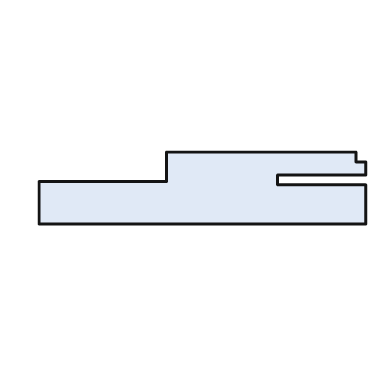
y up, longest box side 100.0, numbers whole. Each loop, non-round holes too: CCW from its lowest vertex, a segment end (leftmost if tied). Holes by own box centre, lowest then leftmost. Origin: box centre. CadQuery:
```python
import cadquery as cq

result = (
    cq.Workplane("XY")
    .moveTo(-50.0, -11.0)
    .lineTo(50.0, -11.0)
    .lineTo(50.0, 1.0)
    .lineTo(23.0, 1.0)
    .lineTo(23.0, 4.0)
    .lineTo(50.0, 4.0)
    .lineTo(50.0, 8.0)
    .lineTo(47.0, 8.0)
    .lineTo(47.0, 11.0)
    .lineTo(-11.0, 11.0)
    .lineTo(-11.0, 2.0)
    .lineTo(-50.0, 2.0)
    .close()
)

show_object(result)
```